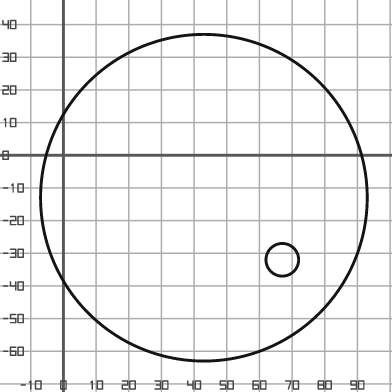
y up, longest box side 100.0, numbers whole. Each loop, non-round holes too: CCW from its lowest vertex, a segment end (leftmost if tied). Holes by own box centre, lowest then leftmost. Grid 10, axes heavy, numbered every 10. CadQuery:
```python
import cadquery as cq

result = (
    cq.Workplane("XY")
    .moveTo(43.0, -13.0)
    .circle(50.0)
    .moveTo(67.0, -32.0)
    .circle(5.0)
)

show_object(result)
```